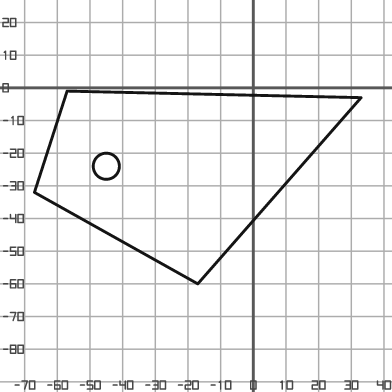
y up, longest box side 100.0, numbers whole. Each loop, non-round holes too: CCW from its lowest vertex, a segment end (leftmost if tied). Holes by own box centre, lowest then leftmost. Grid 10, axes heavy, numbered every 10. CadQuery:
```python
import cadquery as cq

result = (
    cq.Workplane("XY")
    .moveTo(-17.0, -60.0)
    .lineTo(33.0, -3.0)
    .lineTo(-57.0, -1.0)
    .lineTo(-67.0, -32.0)
    .close()
    .moveTo(-45.0, -24.0)
    .circle(4.0)
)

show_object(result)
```